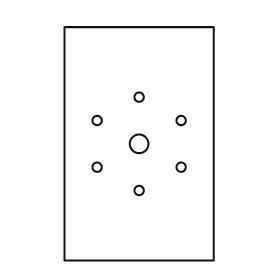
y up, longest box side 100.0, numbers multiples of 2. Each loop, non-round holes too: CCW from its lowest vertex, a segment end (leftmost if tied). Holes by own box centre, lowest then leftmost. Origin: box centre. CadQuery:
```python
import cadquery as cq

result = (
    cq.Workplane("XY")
    .moveTo(-32.0, -50.0)
    .lineTo(32.0, -50.0)
    .lineTo(32.0, 50.0)
    .lineTo(-32.0, 50.0)
    .close()
    .moveTo(0.0, -20.0)
    .circle(2.0)
    .moveTo(-18.0, -10.0)
    .circle(2.0)
    .moveTo(18.0, -10.0)
    .circle(2.0)
    .moveTo(0.0, 0.0)
    .circle(4.0)
    .moveTo(-18.0, 10.0)
    .circle(2.0)
    .moveTo(18.0, 10.0)
    .circle(2.0)
    .moveTo(0.0, 20.0)
    .circle(2.0)
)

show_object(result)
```